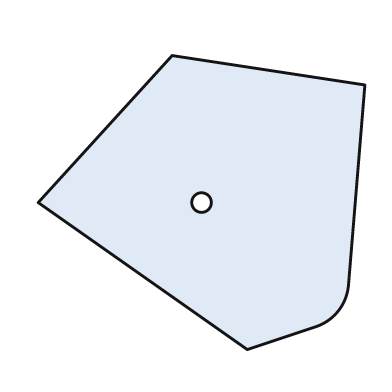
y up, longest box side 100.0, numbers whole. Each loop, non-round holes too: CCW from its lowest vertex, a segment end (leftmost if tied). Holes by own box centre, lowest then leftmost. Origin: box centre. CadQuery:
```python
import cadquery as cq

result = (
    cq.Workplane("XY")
    .moveTo(14.0, -45.0)
    .lineTo(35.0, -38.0)
    .threePointArc((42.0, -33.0), (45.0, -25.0))
    .lineTo(50.0, 36.0)
    .lineTo(-9.0, 45.0)
    .lineTo(-50.0, 0.0)
    .close()
    .moveTo(0.0, 0.0)
    .circle(3.0)
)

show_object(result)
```